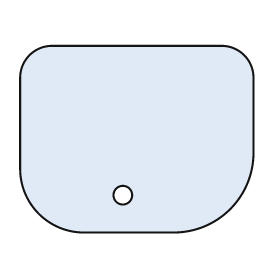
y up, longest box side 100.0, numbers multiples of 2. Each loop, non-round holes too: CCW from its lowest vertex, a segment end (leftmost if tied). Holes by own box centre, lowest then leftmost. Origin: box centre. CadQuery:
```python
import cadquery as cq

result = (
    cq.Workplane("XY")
    .moveTo(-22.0, -40.0)
    .lineTo(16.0, -40.0)
    .threePointArc((40.0, -30.0), (50.0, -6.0))
    .lineTo(50.0, 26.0)
    .threePointArc((46.0, 36.0), (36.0, 40.0))
    .lineTo(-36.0, 40.0)
    .threePointArc((-46.0, 36.0), (-50.0, 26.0))
    .lineTo(-50.0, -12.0)
    .threePointArc((-42.0, -32.0), (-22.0, -40.0))
    .close()
    .moveTo(-6.0, -24.0)
    .circle(4.0)
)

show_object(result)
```